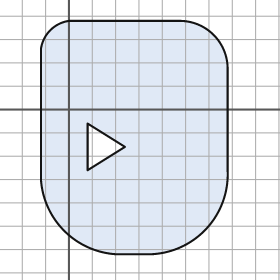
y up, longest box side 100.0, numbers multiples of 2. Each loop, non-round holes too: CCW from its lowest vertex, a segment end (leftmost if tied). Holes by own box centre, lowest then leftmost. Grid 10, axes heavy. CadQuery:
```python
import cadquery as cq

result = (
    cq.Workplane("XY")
    .moveTo(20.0, -62.0)
    .lineTo(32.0, -62.0)
    .threePointArc((58.0, -52.0), (68.0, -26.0))
    .lineTo(68.0, 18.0)
    .threePointArc((62.0, 32.0), (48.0, 38.0))
    .lineTo(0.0, 38.0)
    .threePointArc((-8.0, 34.0), (-12.0, 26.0))
    .lineTo(-12.0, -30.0)
    .threePointArc((-2.0, -52.0), (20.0, -62.0))
    .close()
    .moveTo(8.0, -26.0)
    .lineTo(24.0, -16.0)
    .lineTo(8.0, -6.0)
    .close()
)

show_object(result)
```